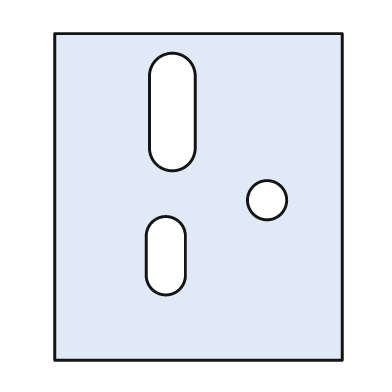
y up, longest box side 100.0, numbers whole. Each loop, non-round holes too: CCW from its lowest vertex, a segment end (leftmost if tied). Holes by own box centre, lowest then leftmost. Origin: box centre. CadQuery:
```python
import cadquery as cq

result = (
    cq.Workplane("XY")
    .moveTo(-44.0, -50.0)
    .lineTo(44.0, -50.0)
    .lineTo(44.0, 50.0)
    .lineTo(-44.0, 50.0)
    .close()
    .moveTo(-16.0, -24.0)
    .threePointArc((-10.0, -30.0), (-4.0, -24.0))
    .lineTo(-4.0, -12.0)
    .threePointArc((-10.0, -6.0), (-16.0, -12.0))
    .close()
    .moveTo(21.0, -1.0)
    .circle(6.0)
    .moveTo(-15.0, 15.0)
    .threePointArc((-8.0, 8.0), (-1.0, 15.0))
    .lineTo(-1.0, 37.0)
    .threePointArc((-8.0, 44.0), (-15.0, 37.0))
    .close()
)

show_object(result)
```